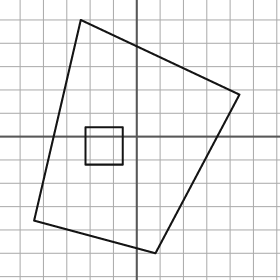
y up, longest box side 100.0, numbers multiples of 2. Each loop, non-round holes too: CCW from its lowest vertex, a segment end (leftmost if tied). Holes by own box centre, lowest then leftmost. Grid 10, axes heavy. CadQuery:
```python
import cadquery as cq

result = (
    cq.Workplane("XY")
    .moveTo(8.0, -50.0)
    .lineTo(44.0, 18.0)
    .lineTo(-24.0, 50.0)
    .lineTo(-44.0, -36.0)
    .close()
    .moveTo(-22.0, -12.0)
    .lineTo(-6.0, -12.0)
    .lineTo(-6.0, 4.0)
    .lineTo(-22.0, 4.0)
    .close()
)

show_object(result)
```